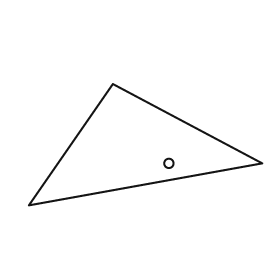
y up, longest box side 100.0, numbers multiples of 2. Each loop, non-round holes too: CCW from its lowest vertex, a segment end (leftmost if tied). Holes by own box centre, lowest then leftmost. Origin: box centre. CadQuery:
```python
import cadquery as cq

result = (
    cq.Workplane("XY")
    .moveTo(-50.0, -26.0)
    .lineTo(50.0, -8.0)
    .lineTo(-14.0, 26.0)
    .close()
    .moveTo(10.0, -8.0)
    .circle(2.0)
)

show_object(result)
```